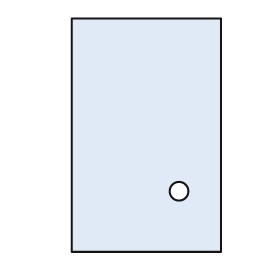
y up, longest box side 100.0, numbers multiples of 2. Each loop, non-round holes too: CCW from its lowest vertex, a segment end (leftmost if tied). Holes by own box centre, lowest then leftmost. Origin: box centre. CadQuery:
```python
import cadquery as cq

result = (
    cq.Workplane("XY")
    .moveTo(-32.0, -50.0)
    .lineTo(32.0, -50.0)
    .lineTo(32.0, 50.0)
    .lineTo(-32.0, 50.0)
    .close()
    .moveTo(14.0, -24.0)
    .circle(4.0)
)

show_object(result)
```